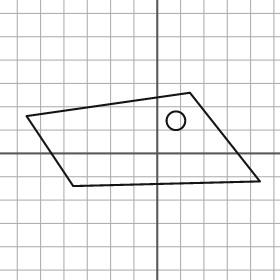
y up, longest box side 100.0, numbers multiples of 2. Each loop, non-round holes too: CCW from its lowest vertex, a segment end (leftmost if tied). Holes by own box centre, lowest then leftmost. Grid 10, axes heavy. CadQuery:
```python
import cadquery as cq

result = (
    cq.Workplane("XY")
    .moveTo(-36.0, -14.0)
    .lineTo(44.0, -12.0)
    .lineTo(14.0, 26.0)
    .lineTo(-56.0, 16.0)
    .close()
    .moveTo(8.0, 14.0)
    .circle(4.0)
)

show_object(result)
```